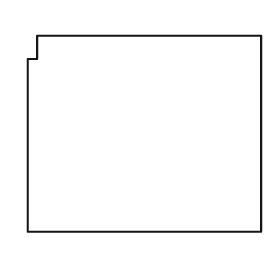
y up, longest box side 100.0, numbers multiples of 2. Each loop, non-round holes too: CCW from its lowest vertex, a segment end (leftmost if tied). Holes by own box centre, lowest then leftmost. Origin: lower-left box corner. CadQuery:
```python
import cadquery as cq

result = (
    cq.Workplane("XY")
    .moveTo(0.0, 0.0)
    .lineTo(100.0, 0.0)
    .lineTo(100.0, 84.0)
    .lineTo(4.0, 84.0)
    .lineTo(4.0, 74.0)
    .lineTo(0.0, 74.0)
    .close()
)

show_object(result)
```